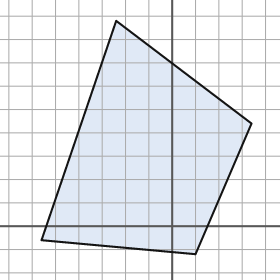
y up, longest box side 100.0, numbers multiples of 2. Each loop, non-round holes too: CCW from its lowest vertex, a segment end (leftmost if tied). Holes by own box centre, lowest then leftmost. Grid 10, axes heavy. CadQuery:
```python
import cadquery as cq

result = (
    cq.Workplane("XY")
    .moveTo(10.0, -12.0)
    .lineTo(34.0, 44.0)
    .lineTo(-24.0, 88.0)
    .lineTo(-56.0, -6.0)
    .close()
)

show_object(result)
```